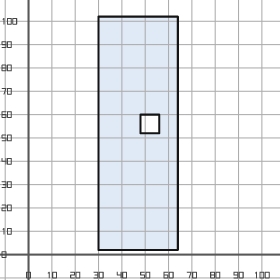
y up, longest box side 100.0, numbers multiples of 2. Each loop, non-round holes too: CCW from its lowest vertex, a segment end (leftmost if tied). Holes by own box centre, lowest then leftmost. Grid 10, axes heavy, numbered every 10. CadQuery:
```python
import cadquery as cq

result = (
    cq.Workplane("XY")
    .moveTo(30.0, 2.0)
    .lineTo(64.0, 2.0)
    .lineTo(64.0, 102.0)
    .lineTo(30.0, 102.0)
    .close()
    .moveTo(48.0, 52.0)
    .lineTo(56.0, 52.0)
    .lineTo(56.0, 60.0)
    .lineTo(48.0, 60.0)
    .close()
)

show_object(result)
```